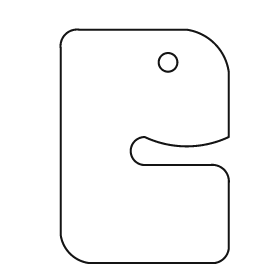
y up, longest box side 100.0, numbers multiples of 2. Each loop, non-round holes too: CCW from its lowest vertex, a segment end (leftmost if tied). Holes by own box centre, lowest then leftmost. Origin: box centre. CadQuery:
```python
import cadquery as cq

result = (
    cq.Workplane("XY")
    .moveTo(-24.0, -50.0)
    .lineTo(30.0, -50.0)
    .threePointArc((34.0, -48.0), (36.0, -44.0))
    .lineTo(36.0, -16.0)
    .threePointArc((34.0, -10.0), (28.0, -8.0))
    .lineTo(0.0, -8.0)
    .threePointArc((-6.0, -2.0), (0.0, 4.0))
    .threePointArc((18.0, 0.0), (36.0, 4.0))
    .lineTo(36.0, 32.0)
    .threePointArc((30.0, 44.0), (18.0, 50.0))
    .lineTo(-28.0, 50.0)
    .threePointArc((-34.0, 48.0), (-36.0, 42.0))
    .lineTo(-36.0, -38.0)
    .threePointArc((-32.0, -46.0), (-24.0, -50.0))
    .close()
    .moveTo(10.0, 36.0)
    .circle(4.0)
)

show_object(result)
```